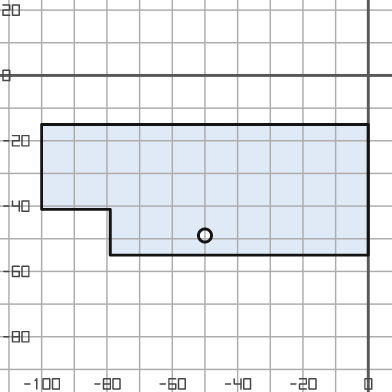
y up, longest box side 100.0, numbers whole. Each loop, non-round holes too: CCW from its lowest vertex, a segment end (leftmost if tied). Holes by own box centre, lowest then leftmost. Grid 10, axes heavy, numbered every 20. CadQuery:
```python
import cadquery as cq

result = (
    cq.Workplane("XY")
    .moveTo(-79.0, -55.0)
    .lineTo(0.0, -55.0)
    .lineTo(0.0, -15.0)
    .lineTo(-100.0, -15.0)
    .lineTo(-100.0, -41.0)
    .lineTo(-79.0, -41.0)
    .close()
    .moveTo(-50.0, -49.0)
    .circle(2.0)
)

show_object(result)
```